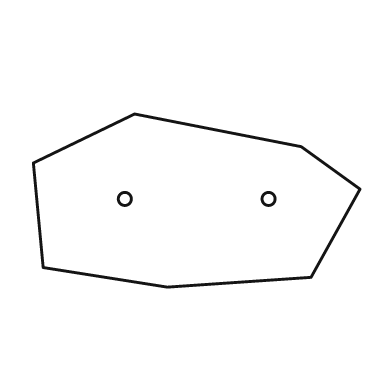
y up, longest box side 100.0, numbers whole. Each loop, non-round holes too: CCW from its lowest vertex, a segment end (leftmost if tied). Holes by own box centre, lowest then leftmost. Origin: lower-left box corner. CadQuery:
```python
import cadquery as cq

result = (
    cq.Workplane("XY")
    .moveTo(41.0, 0.0)
    .lineTo(85.0, 3.0)
    .lineTo(100.0, 30.0)
    .lineTo(82.0, 43.0)
    .lineTo(31.0, 53.0)
    .lineTo(0.0, 38.0)
    .lineTo(3.0, 6.0)
    .close()
    .moveTo(28.0, 27.0)
    .circle(2.0)
    .moveTo(72.0, 27.0)
    .circle(2.0)
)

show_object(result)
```